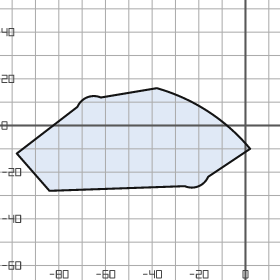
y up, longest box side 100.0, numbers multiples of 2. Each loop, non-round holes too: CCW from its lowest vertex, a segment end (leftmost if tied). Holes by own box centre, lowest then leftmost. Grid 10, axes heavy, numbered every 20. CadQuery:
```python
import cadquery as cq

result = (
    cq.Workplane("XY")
    .moveTo(-84.0, -28.0)
    .lineTo(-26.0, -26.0)
    .threePointArc((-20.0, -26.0), (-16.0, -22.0))
    .lineTo(2.0, -10.0)
    .threePointArc((-16.0, 6.0), (-38.0, 16.0))
    .lineTo(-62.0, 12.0)
    .threePointArc((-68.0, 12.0), (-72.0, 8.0))
    .lineTo(-98.0, -12.0)
    .close()
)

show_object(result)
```